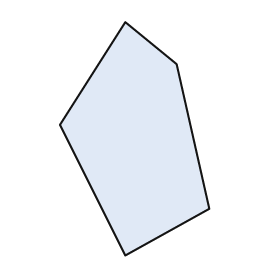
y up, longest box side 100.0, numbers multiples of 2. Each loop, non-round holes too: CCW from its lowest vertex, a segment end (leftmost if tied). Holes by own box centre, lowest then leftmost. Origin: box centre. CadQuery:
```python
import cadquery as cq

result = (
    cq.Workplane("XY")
    .moveTo(-4.0, -50.0)
    .lineTo(32.0, -30.0)
    .lineTo(18.0, 32.0)
    .lineTo(-4.0, 50.0)
    .lineTo(-32.0, 6.0)
    .close()
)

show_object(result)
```